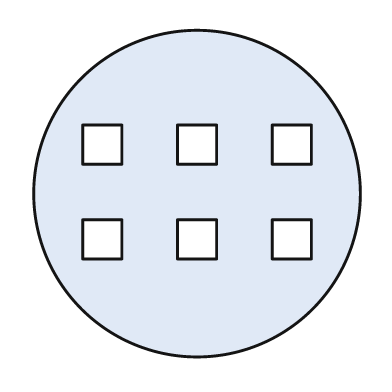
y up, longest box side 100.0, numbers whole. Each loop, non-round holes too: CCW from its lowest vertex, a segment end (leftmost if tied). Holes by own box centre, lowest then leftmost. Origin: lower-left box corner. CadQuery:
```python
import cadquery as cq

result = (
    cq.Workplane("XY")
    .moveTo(50.0, 50.0)
    .circle(50.0)
    .moveTo(15.0, 30.0)
    .lineTo(27.0, 30.0)
    .lineTo(27.0, 42.0)
    .lineTo(15.0, 42.0)
    .close()
    .moveTo(44.0, 30.0)
    .lineTo(56.0, 30.0)
    .lineTo(56.0, 42.0)
    .lineTo(44.0, 42.0)
    .close()
    .moveTo(73.0, 30.0)
    .lineTo(85.0, 30.0)
    .lineTo(85.0, 42.0)
    .lineTo(73.0, 42.0)
    .close()
    .moveTo(15.0, 59.0)
    .lineTo(27.0, 59.0)
    .lineTo(27.0, 71.0)
    .lineTo(15.0, 71.0)
    .close()
    .moveTo(44.0, 59.0)
    .lineTo(56.0, 59.0)
    .lineTo(56.0, 71.0)
    .lineTo(44.0, 71.0)
    .close()
    .moveTo(73.0, 59.0)
    .lineTo(85.0, 59.0)
    .lineTo(85.0, 71.0)
    .lineTo(73.0, 71.0)
    .close()
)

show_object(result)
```